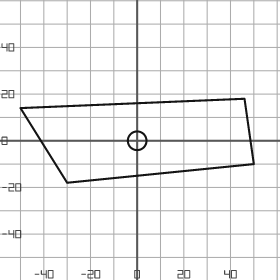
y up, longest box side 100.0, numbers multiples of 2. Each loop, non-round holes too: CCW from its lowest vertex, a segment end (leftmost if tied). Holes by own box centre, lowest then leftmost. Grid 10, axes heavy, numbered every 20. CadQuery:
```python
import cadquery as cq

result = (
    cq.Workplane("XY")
    .moveTo(-30.0, -18.0)
    .lineTo(50.0, -10.0)
    .lineTo(46.0, 18.0)
    .lineTo(-50.0, 14.0)
    .close()
    .moveTo(0.0, 0.0)
    .circle(4.0)
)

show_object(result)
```